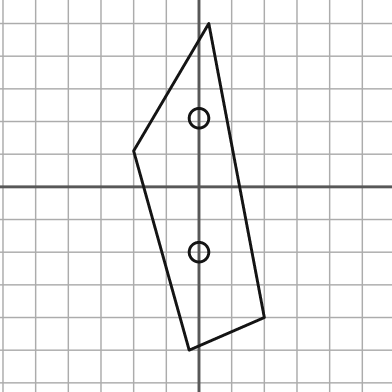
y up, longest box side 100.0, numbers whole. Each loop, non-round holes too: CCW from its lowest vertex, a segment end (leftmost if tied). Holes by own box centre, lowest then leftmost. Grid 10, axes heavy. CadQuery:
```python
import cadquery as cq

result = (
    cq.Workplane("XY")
    .moveTo(-3.0, -50.0)
    .lineTo(20.0, -40.0)
    .lineTo(3.0, 50.0)
    .lineTo(-20.0, 11.0)
    .close()
    .moveTo(0.0, -20.0)
    .circle(3.0)
    .moveTo(0.0, 21.0)
    .circle(3.0)
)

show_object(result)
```